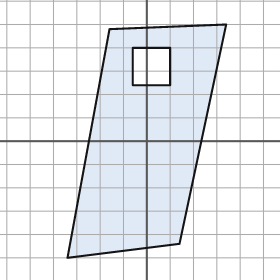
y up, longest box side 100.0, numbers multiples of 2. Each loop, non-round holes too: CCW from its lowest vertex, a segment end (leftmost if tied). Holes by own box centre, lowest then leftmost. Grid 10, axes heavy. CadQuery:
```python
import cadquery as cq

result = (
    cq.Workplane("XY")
    .moveTo(-34.0, -50.0)
    .lineTo(14.0, -44.0)
    .lineTo(34.0, 50.0)
    .lineTo(-16.0, 48.0)
    .close()
    .moveTo(-6.0, 24.0)
    .lineTo(10.0, 24.0)
    .lineTo(10.0, 40.0)
    .lineTo(-6.0, 40.0)
    .close()
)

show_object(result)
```